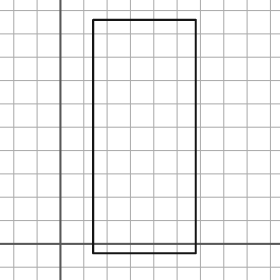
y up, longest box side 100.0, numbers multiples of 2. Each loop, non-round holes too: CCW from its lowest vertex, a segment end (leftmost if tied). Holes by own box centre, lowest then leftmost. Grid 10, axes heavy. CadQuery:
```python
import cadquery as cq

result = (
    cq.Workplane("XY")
    .moveTo(14.0, -4.0)
    .lineTo(58.0, -4.0)
    .lineTo(58.0, 96.0)
    .lineTo(14.0, 96.0)
    .close()
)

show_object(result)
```